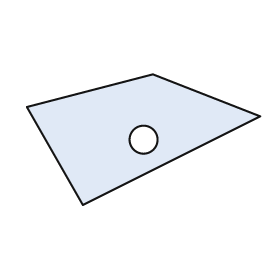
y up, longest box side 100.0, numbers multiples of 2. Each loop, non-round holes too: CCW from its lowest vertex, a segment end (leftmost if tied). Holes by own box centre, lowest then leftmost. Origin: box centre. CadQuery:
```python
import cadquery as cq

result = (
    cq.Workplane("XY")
    .moveTo(-26.0, -28.0)
    .lineTo(50.0, 10.0)
    .lineTo(4.0, 28.0)
    .lineTo(-50.0, 14.0)
    .close()
    .moveTo(0.0, 0.0)
    .circle(6.0)
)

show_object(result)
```